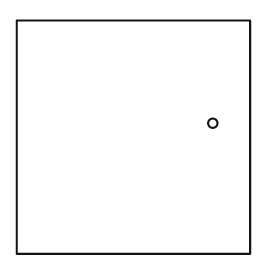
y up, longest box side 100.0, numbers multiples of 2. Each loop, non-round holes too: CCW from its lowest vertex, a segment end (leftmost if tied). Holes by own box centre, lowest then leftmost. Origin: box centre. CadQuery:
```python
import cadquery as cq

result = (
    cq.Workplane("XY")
    .moveTo(-50.0, -50.0)
    .lineTo(50.0, -50.0)
    .lineTo(50.0, 50.0)
    .lineTo(-50.0, 50.0)
    .close()
    .moveTo(34.0, 6.0)
    .circle(2.0)
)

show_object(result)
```